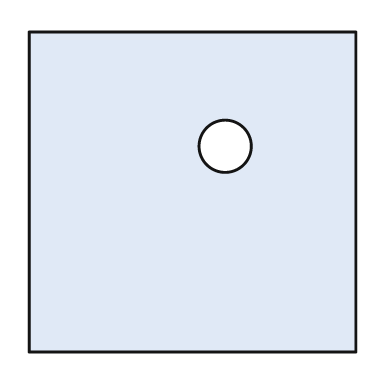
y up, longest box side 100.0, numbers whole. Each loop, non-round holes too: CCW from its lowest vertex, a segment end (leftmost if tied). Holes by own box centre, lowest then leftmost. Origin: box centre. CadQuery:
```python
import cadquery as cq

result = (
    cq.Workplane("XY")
    .moveTo(-50.0, -49.0)
    .lineTo(50.0, -49.0)
    .lineTo(50.0, 49.0)
    .lineTo(-50.0, 49.0)
    .close()
    .moveTo(10.0, 14.0)
    .circle(8.0)
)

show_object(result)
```